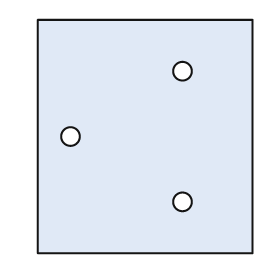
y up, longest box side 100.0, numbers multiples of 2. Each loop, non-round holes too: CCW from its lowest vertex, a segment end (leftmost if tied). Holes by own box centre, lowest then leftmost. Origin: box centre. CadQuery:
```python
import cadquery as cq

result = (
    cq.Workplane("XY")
    .moveTo(-46.0, -50.0)
    .lineTo(46.0, -50.0)
    .lineTo(46.0, 50.0)
    .lineTo(-46.0, 50.0)
    .close()
    .moveTo(16.0, -28.0)
    .circle(4.0)
    .moveTo(-32.0, 0.0)
    .circle(4.0)
    .moveTo(16.0, 28.0)
    .circle(4.0)
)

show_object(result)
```